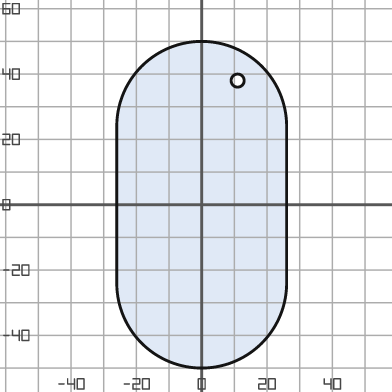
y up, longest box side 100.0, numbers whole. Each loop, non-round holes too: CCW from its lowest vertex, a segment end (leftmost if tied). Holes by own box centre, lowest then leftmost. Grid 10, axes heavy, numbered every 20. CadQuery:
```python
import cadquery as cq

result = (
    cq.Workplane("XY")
    .moveTo(-26.0, -24.0)
    .threePointArc((0.0, -50.0), (26.0, -24.0))
    .lineTo(26.0, 24.0)
    .threePointArc((0.0, 50.0), (-26.0, 24.0))
    .close()
    .moveTo(11.0, 38.0)
    .circle(2.0)
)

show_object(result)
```